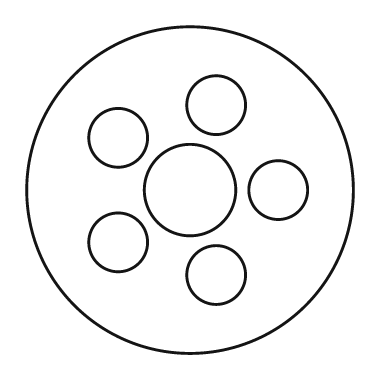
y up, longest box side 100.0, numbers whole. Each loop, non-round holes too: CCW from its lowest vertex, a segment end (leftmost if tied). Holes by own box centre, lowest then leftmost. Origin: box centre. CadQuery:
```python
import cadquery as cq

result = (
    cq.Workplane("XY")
    .moveTo(0.0, 0.0)
    .circle(50.0)
    .moveTo(8.0, -26.0)
    .circle(9.0)
    .moveTo(-22.0, -16.0)
    .circle(9.0)
    .moveTo(0.0, 0.0)
    .circle(14.0)
    .moveTo(27.0, 0.0)
    .circle(9.0)
    .moveTo(-22.0, 16.0)
    .circle(9.0)
    .moveTo(8.0, 26.0)
    .circle(9.0)
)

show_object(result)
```